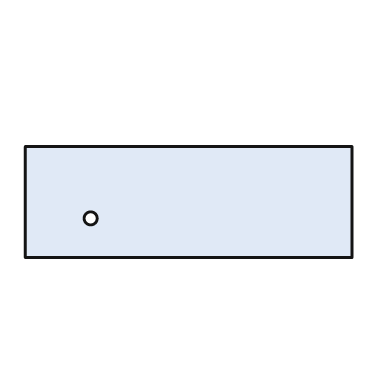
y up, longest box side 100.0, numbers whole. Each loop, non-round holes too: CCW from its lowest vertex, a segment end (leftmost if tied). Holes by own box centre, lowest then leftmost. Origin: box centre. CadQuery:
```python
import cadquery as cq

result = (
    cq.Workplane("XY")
    .moveTo(-50.0, -17.0)
    .lineTo(50.0, -17.0)
    .lineTo(50.0, 17.0)
    .lineTo(-50.0, 17.0)
    .close()
    .moveTo(-30.0, -5.0)
    .circle(2.0)
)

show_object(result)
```